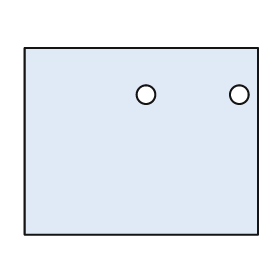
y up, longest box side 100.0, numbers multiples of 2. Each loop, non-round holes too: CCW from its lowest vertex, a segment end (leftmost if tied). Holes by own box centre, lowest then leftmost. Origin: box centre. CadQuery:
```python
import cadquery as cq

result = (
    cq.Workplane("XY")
    .moveTo(-50.0, -40.0)
    .lineTo(50.0, -40.0)
    .lineTo(50.0, 40.0)
    .lineTo(-50.0, 40.0)
    .close()
    .moveTo(2.0, 20.0)
    .circle(4.0)
    .moveTo(42.0, 20.0)
    .circle(4.0)
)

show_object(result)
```